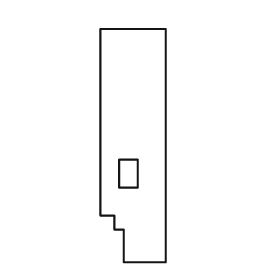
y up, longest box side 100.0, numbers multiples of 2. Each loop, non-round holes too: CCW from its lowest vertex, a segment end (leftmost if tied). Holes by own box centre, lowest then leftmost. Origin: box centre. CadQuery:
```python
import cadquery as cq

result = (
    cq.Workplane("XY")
    .moveTo(-4.0, -50.0)
    .lineTo(14.0, -50.0)
    .lineTo(14.0, 50.0)
    .lineTo(-14.0, 50.0)
    .lineTo(-14.0, -30.0)
    .lineTo(-8.0, -30.0)
    .lineTo(-8.0, -36.0)
    .lineTo(-4.0, -36.0)
    .close()
    .moveTo(-6.0, -18.0)
    .lineTo(2.0, -18.0)
    .lineTo(2.0, -6.0)
    .lineTo(-6.0, -6.0)
    .close()
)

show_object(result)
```